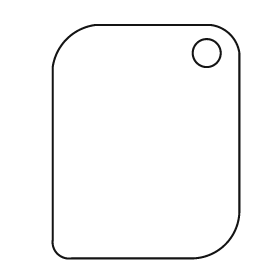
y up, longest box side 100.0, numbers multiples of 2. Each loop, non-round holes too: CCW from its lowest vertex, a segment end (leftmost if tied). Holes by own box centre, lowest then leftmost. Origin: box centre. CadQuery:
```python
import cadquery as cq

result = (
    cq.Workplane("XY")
    .moveTo(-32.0, -50.0)
    .lineTo(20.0, -50.0)
    .threePointArc((34.0, -44.0), (40.0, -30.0))
    .lineTo(40.0, 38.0)
    .threePointArc((36.0, 46.0), (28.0, 50.0))
    .lineTo(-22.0, 50.0)
    .threePointArc((-34.0, 44.0), (-40.0, 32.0))
    .lineTo(-40.0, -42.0)
    .threePointArc((-38.0, -48.0), (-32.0, -50.0))
    .close()
    .moveTo(26.0, 38.0)
    .circle(6.0)
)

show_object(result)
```